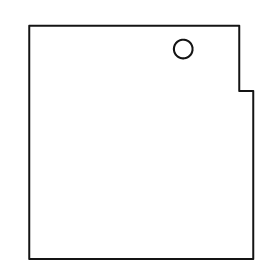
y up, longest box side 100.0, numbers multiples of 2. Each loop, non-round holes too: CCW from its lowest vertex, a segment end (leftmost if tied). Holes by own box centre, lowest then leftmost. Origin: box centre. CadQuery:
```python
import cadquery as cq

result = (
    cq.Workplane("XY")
    .moveTo(-48.0, -50.0)
    .lineTo(48.0, -50.0)
    .lineTo(48.0, 22.0)
    .lineTo(42.0, 22.0)
    .lineTo(42.0, 50.0)
    .lineTo(-48.0, 50.0)
    .close()
    .moveTo(18.0, 40.0)
    .circle(4.0)
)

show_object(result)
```